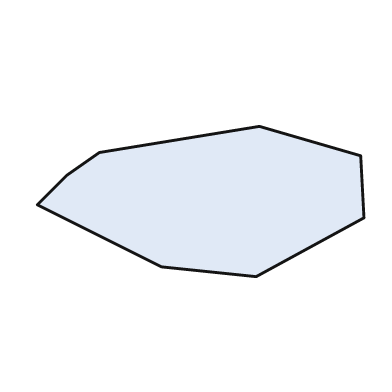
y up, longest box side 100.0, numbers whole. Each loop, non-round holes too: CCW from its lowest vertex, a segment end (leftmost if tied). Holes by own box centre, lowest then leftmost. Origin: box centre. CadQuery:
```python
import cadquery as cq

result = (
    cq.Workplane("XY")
    .moveTo(17.0, -23.0)
    .lineTo(50.0, -5.0)
    .lineTo(49.0, 14.0)
    .lineTo(18.0, 23.0)
    .lineTo(-31.0, 15.0)
    .lineTo(-41.0, 8.0)
    .lineTo(-50.0, -1.0)
    .lineTo(-12.0, -20.0)
    .close()
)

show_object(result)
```